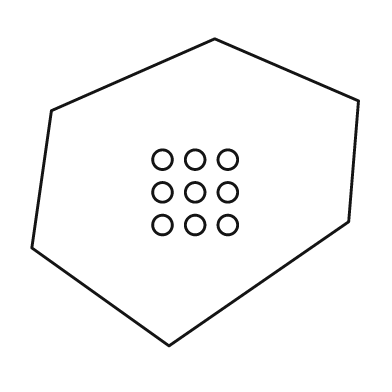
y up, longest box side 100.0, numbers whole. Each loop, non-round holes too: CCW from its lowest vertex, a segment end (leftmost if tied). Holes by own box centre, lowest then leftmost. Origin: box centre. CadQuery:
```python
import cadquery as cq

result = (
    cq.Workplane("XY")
    .moveTo(-8.0, -47.0)
    .lineTo(47.0, -9.0)
    .lineTo(50.0, 28.0)
    .lineTo(6.0, 47.0)
    .lineTo(-44.0, 25.0)
    .lineTo(-50.0, -17.0)
    .close()
    .moveTo(-10.0, -10.0)
    .circle(3.0)
    .moveTo(0.0, -10.0)
    .circle(3.0)
    .moveTo(10.0, -10.0)
    .circle(3.0)
    .moveTo(-10.0, 0.0)
    .circle(3.0)
    .moveTo(0.0, 0.0)
    .circle(3.0)
    .moveTo(10.0, 0.0)
    .circle(3.0)
    .moveTo(-10.0, 10.0)
    .circle(3.0)
    .moveTo(0.0, 10.0)
    .circle(3.0)
    .moveTo(10.0, 10.0)
    .circle(3.0)
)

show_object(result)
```